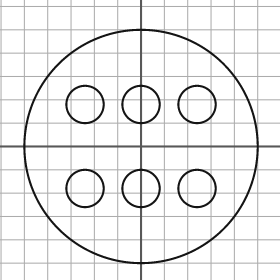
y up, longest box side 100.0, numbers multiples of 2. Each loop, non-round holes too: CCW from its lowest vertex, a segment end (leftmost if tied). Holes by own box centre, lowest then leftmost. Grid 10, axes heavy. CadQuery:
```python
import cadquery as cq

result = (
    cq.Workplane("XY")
    .moveTo(0.0, 0.0)
    .circle(50.0)
    .moveTo(-24.0, -18.0)
    .circle(8.0)
    .moveTo(0.0, -18.0)
    .circle(8.0)
    .moveTo(24.0, -18.0)
    .circle(8.0)
    .moveTo(-24.0, 18.0)
    .circle(8.0)
    .moveTo(0.0, 18.0)
    .circle(8.0)
    .moveTo(24.0, 18.0)
    .circle(8.0)
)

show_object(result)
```